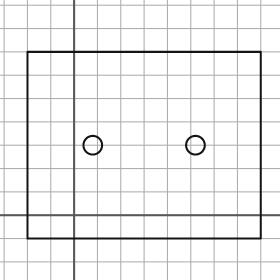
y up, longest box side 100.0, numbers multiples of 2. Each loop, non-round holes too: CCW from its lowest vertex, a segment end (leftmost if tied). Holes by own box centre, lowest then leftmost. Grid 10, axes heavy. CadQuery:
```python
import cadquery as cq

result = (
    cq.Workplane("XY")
    .moveTo(-20.0, -10.0)
    .lineTo(80.0, -10.0)
    .lineTo(80.0, 70.0)
    .lineTo(-20.0, 70.0)
    .close()
    .moveTo(8.0, 30.0)
    .circle(4.0)
    .moveTo(52.0, 30.0)
    .circle(4.0)
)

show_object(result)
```